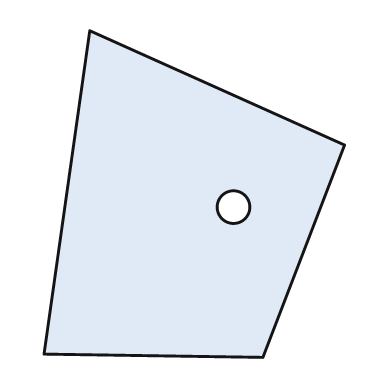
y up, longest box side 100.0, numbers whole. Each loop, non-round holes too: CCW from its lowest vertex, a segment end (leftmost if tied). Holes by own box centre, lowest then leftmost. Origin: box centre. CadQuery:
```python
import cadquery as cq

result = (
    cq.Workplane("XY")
    .moveTo(21.0, -50.0)
    .lineTo(46.0, 15.0)
    .lineTo(-32.0, 50.0)
    .lineTo(-46.0, -49.0)
    .close()
    .moveTo(12.0, -4.0)
    .circle(5.0)
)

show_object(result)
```